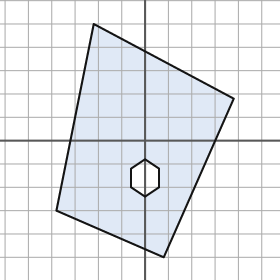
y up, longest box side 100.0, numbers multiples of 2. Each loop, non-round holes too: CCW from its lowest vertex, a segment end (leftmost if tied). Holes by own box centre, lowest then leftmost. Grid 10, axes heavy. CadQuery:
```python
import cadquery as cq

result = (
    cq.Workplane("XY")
    .moveTo(8.0, -50.0)
    .lineTo(38.0, 18.0)
    .lineTo(-22.0, 50.0)
    .lineTo(-38.0, -30.0)
    .close()
    .moveTo(0.0, -24.0)
    .lineTo(6.0, -20.0)
    .lineTo(6.0, -12.0)
    .lineTo(0.0, -8.0)
    .lineTo(-6.0, -12.0)
    .lineTo(-6.0, -20.0)
    .close()
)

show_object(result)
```